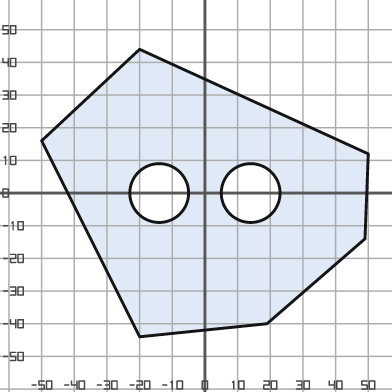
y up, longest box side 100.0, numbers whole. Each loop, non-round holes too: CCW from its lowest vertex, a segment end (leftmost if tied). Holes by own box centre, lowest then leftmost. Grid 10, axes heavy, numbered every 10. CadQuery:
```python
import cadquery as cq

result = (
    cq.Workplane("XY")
    .moveTo(-20.0, -44.0)
    .lineTo(19.0, -40.0)
    .lineTo(49.0, -14.0)
    .lineTo(50.0, 12.0)
    .lineTo(-20.0, 44.0)
    .lineTo(-50.0, 16.0)
    .close()
    .moveTo(-14.0, 0.0)
    .circle(9.0)
    .moveTo(14.0, 0.0)
    .circle(9.0)
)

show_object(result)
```